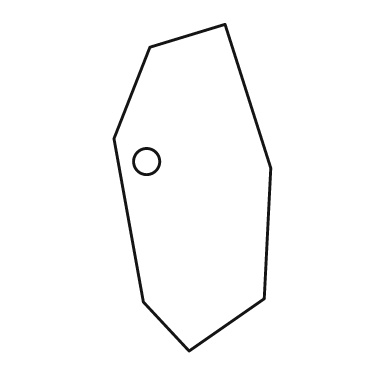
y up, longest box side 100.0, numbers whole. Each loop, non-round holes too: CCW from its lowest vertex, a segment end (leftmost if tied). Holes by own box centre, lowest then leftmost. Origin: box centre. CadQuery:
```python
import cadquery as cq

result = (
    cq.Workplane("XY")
    .moveTo(-1.0, -50.0)
    .lineTo(22.0, -34.0)
    .lineTo(24.0, 6.0)
    .lineTo(10.0, 50.0)
    .lineTo(-13.0, 43.0)
    .lineTo(-24.0, 15.0)
    .lineTo(-15.0, -35.0)
    .close()
    .moveTo(-14.0, 8.0)
    .circle(4.0)
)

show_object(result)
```